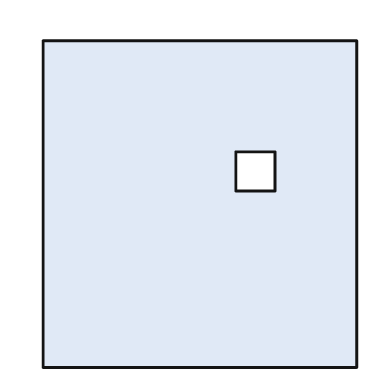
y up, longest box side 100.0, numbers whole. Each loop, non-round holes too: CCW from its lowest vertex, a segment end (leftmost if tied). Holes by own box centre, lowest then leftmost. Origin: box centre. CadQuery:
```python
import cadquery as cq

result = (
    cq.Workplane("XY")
    .moveTo(-48.0, -50.0)
    .lineTo(48.0, -50.0)
    .lineTo(48.0, 50.0)
    .lineTo(-48.0, 50.0)
    .close()
    .moveTo(11.0, 4.0)
    .lineTo(23.0, 4.0)
    .lineTo(23.0, 16.0)
    .lineTo(11.0, 16.0)
    .close()
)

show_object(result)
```